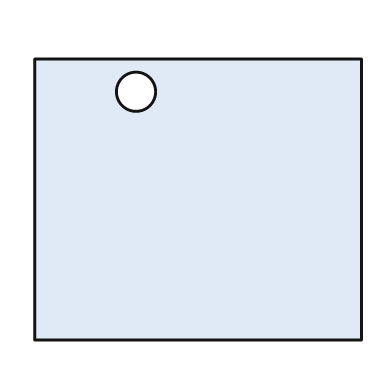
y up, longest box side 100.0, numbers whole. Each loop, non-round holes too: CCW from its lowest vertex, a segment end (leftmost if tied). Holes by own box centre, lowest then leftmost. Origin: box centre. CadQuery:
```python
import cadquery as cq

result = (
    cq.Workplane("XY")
    .moveTo(-50.0, -43.0)
    .lineTo(50.0, -43.0)
    .lineTo(50.0, 43.0)
    .lineTo(-50.0, 43.0)
    .close()
    .moveTo(-19.0, 33.0)
    .circle(6.0)
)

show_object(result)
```